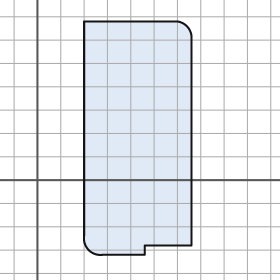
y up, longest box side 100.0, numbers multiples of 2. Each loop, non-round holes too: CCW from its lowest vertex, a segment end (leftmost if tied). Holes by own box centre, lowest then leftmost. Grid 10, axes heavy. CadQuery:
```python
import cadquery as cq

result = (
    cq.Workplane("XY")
    .moveTo(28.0, -32.0)
    .lineTo(46.0, -32.0)
    .lineTo(46.0, -28.0)
    .lineTo(66.0, -28.0)
    .lineTo(66.0, 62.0)
    .threePointArc((64.0, 66.0), (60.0, 68.0))
    .lineTo(20.0, 68.0)
    .lineTo(20.0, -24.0)
    .threePointArc((22.0, -30.0), (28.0, -32.0))
    .close()
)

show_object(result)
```